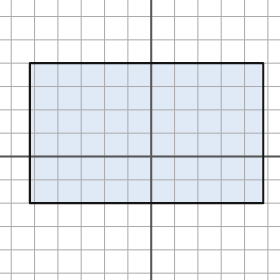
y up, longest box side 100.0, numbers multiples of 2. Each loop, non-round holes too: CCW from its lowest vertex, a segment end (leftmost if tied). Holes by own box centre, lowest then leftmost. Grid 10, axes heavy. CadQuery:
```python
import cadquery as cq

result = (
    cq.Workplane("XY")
    .moveTo(-52.0, -20.0)
    .lineTo(48.0, -20.0)
    .lineTo(48.0, 40.0)
    .lineTo(-52.0, 40.0)
    .close()
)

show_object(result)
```